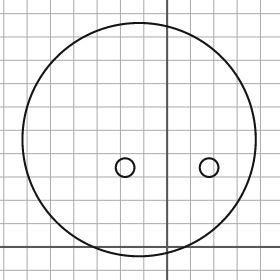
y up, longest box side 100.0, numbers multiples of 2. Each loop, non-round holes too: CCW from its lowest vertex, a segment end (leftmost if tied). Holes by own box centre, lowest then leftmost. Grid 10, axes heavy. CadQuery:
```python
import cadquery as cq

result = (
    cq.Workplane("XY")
    .moveTo(-12.0, 46.0)
    .circle(50.0)
    .moveTo(-18.0, 34.0)
    .circle(4.0)
    .moveTo(18.0, 34.0)
    .circle(4.0)
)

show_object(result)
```